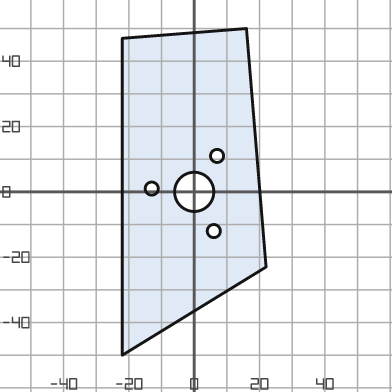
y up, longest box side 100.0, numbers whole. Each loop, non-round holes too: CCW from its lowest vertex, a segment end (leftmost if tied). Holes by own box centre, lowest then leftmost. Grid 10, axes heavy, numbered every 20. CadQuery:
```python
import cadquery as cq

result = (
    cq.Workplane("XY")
    .moveTo(-22.0, -50.0)
    .lineTo(22.0, -23.0)
    .lineTo(16.0, 50.0)
    .lineTo(-22.0, 47.0)
    .close()
    .moveTo(6.0, -12.0)
    .circle(2.0)
    .moveTo(0.0, 0.0)
    .circle(6.0)
    .moveTo(-13.0, 1.0)
    .circle(2.0)
    .moveTo(7.0, 11.0)
    .circle(2.0)
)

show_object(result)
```